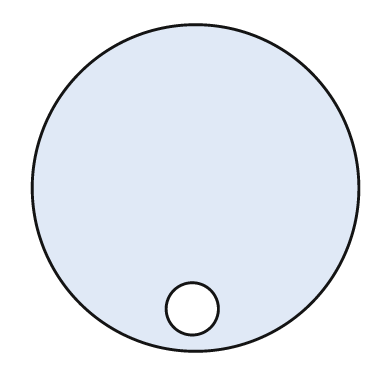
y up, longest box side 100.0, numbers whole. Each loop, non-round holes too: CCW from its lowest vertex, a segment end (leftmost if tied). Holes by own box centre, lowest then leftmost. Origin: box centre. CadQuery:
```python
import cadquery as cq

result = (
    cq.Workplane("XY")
    .moveTo(0.0, 0.0)
    .circle(50.0)
    .moveTo(-1.0, -37.0)
    .circle(8.0)
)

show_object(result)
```